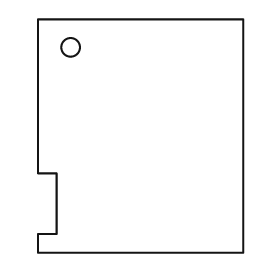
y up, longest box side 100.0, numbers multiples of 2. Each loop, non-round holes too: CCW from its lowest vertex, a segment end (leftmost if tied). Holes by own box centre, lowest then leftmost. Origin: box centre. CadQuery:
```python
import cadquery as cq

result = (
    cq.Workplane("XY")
    .moveTo(-44.0, -50.0)
    .lineTo(44.0, -50.0)
    .lineTo(44.0, 50.0)
    .lineTo(-44.0, 50.0)
    .lineTo(-44.0, -16.0)
    .lineTo(-36.0, -16.0)
    .lineTo(-36.0, -42.0)
    .lineTo(-44.0, -42.0)
    .close()
    .moveTo(-30.0, 38.0)
    .circle(4.0)
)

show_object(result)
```